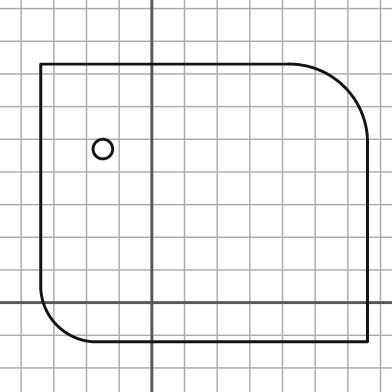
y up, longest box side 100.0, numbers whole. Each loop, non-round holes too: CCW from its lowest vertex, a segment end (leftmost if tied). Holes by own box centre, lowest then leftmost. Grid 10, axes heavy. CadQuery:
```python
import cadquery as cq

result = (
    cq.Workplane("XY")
    .moveTo(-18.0, -12.0)
    .lineTo(66.0, -12.0)
    .lineTo(66.0, 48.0)
    .threePointArc((59.0, 66.0), (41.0, 73.0))
    .lineTo(-34.0, 73.0)
    .lineTo(-34.0, 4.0)
    .threePointArc((-29.0, -7.0), (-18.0, -12.0))
    .close()
    .moveTo(-15.0, 47.0)
    .circle(3.0)
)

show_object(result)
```